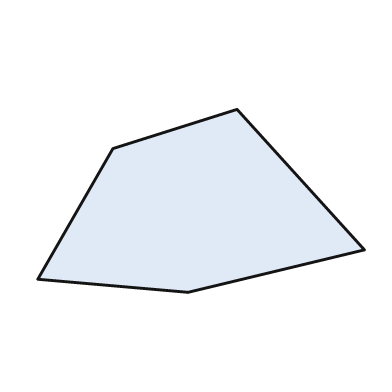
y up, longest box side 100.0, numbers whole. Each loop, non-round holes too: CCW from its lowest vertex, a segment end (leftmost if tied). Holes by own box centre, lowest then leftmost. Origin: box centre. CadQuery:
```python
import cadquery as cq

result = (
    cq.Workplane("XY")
    .moveTo(-4.0, -28.0)
    .lineTo(50.0, -15.0)
    .lineTo(11.0, 28.0)
    .lineTo(-27.0, 16.0)
    .lineTo(-50.0, -24.0)
    .close()
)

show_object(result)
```